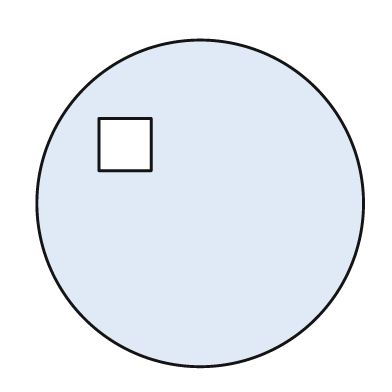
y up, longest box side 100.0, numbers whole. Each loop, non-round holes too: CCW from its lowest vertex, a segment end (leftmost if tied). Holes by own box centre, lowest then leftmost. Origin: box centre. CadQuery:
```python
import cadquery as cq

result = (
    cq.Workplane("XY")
    .moveTo(0.0, 0.0)
    .circle(50.0)
    .moveTo(-31.0, 10.0)
    .lineTo(-15.0, 10.0)
    .lineTo(-15.0, 26.0)
    .lineTo(-31.0, 26.0)
    .close()
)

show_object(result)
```